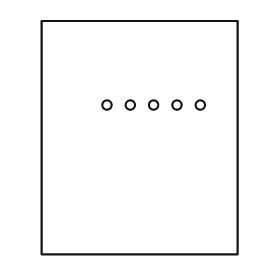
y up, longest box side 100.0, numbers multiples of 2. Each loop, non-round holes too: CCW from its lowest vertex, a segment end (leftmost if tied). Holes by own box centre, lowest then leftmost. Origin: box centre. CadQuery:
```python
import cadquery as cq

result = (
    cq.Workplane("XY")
    .moveTo(-42.0, -50.0)
    .lineTo(42.0, -50.0)
    .lineTo(42.0, 50.0)
    .lineTo(-42.0, 50.0)
    .close()
    .moveTo(-14.0, 14.0)
    .circle(2.0)
    .moveTo(-4.0, 14.0)
    .circle(2.0)
    .moveTo(6.0, 14.0)
    .circle(2.0)
    .moveTo(16.0, 14.0)
    .circle(2.0)
    .moveTo(26.0, 14.0)
    .circle(2.0)
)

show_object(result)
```